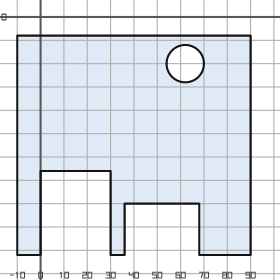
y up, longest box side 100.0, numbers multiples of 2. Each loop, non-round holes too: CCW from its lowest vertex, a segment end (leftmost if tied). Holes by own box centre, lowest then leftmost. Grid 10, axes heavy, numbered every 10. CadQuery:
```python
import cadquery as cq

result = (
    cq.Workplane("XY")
    .moveTo(-10.0, -102.0)
    .lineTo(0.0, -102.0)
    .lineTo(0.0, -66.0)
    .lineTo(30.0, -66.0)
    .lineTo(30.0, -102.0)
    .lineTo(36.0, -102.0)
    .lineTo(36.0, -80.0)
    .lineTo(68.0, -80.0)
    .lineTo(68.0, -102.0)
    .lineTo(90.0, -102.0)
    .lineTo(90.0, -8.0)
    .lineTo(-10.0, -8.0)
    .close()
    .moveTo(62.0, -20.0)
    .circle(8.0)
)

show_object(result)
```